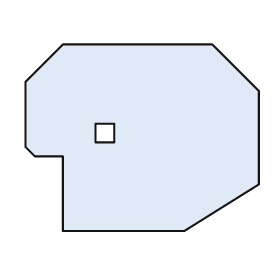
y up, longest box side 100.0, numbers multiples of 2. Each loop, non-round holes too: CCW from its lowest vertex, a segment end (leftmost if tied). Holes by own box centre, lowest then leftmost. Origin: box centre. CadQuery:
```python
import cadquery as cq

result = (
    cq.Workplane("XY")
    .moveTo(-34.0, -40.0)
    .lineTo(18.0, -40.0)
    .lineTo(50.0, -20.0)
    .lineTo(50.0, 20.0)
    .lineTo(30.0, 40.0)
    .lineTo(-34.0, 40.0)
    .lineTo(-50.0, 24.0)
    .lineTo(-50.0, -4.0)
    .lineTo(-46.0, -8.0)
    .lineTo(-34.0, -8.0)
    .close()
    .moveTo(-20.0, -2.0)
    .lineTo(-12.0, -2.0)
    .lineTo(-12.0, 6.0)
    .lineTo(-20.0, 6.0)
    .close()
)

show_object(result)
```